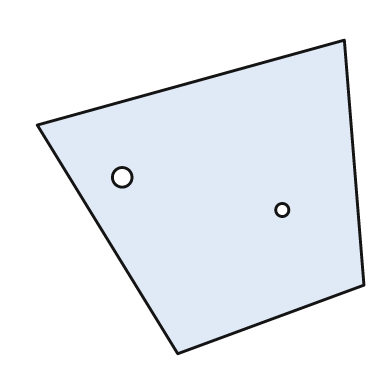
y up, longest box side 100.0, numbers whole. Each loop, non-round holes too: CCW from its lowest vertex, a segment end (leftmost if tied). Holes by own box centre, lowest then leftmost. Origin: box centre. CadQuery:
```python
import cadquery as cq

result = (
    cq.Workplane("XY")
    .moveTo(-7.0, -48.0)
    .lineTo(50.0, -27.0)
    .lineTo(44.0, 48.0)
    .lineTo(-50.0, 22.0)
    .close()
    .moveTo(25.0, -4.0)
    .circle(2.0)
    .moveTo(-24.0, 6.0)
    .circle(3.0)
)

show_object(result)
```